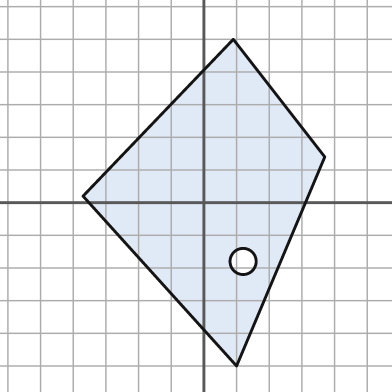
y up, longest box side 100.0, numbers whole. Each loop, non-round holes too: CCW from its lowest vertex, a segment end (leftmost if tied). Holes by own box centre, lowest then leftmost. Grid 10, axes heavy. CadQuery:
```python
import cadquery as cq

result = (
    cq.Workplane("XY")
    .moveTo(10.0, -50.0)
    .lineTo(37.0, 14.0)
    .lineTo(9.0, 50.0)
    .lineTo(-37.0, 2.0)
    .close()
    .moveTo(12.0, -18.0)
    .circle(4.0)
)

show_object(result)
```